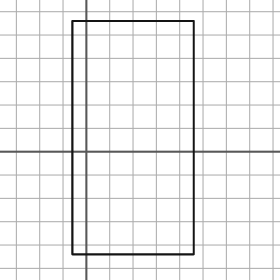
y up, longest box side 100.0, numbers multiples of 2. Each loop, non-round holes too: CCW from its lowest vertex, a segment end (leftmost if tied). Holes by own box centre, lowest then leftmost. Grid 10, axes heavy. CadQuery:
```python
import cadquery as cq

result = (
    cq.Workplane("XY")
    .moveTo(-6.0, -44.0)
    .lineTo(46.0, -44.0)
    .lineTo(46.0, 56.0)
    .lineTo(-6.0, 56.0)
    .close()
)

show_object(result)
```